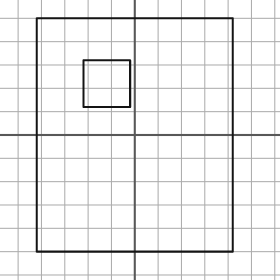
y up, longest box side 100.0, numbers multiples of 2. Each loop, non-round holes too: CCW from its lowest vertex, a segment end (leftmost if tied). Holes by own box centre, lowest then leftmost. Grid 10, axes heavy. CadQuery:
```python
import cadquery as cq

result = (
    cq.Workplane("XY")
    .moveTo(-42.0, -50.0)
    .lineTo(42.0, -50.0)
    .lineTo(42.0, 50.0)
    .lineTo(-42.0, 50.0)
    .close()
    .moveTo(-22.0, 12.0)
    .lineTo(-2.0, 12.0)
    .lineTo(-2.0, 32.0)
    .lineTo(-22.0, 32.0)
    .close()
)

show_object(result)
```